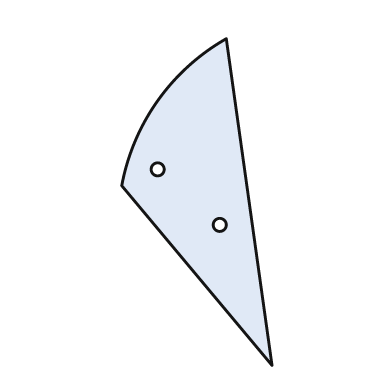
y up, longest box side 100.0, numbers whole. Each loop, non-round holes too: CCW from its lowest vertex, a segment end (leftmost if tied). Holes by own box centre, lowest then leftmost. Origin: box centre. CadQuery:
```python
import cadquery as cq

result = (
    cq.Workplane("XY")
    .moveTo(23.0, -50.0)
    .lineTo(9.0, 50.0)
    .threePointArc((-12.0, 31.0), (-23.0, 5.0))
    .close()
    .moveTo(7.0, -7.0)
    .circle(2.0)
    .moveTo(-12.0, 10.0)
    .circle(2.0)
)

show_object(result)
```